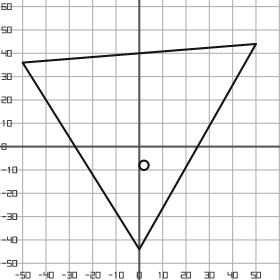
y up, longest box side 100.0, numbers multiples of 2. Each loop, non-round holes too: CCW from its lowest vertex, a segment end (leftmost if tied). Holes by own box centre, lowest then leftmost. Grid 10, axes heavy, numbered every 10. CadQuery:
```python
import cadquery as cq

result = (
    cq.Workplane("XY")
    .moveTo(0.0, -44.0)
    .lineTo(50.0, 44.0)
    .lineTo(-50.0, 36.0)
    .close()
    .moveTo(2.0, -8.0)
    .circle(2.0)
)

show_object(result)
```